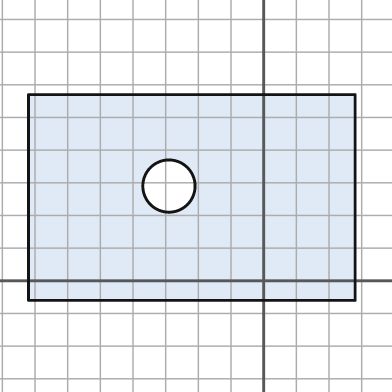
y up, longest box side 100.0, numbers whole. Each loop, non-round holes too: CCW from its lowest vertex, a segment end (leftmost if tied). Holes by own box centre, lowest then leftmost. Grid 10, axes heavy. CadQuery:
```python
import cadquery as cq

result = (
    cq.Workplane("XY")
    .moveTo(-72.0, -6.0)
    .lineTo(28.0, -6.0)
    .lineTo(28.0, 57.0)
    .lineTo(-72.0, 57.0)
    .close()
    .moveTo(-29.0, 29.0)
    .circle(8.0)
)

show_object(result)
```